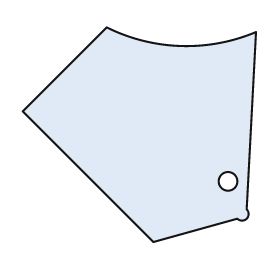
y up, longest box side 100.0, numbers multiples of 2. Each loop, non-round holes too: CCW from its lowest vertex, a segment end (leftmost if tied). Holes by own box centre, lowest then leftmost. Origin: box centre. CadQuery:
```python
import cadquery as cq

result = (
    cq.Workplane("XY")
    .moveTo(6.0, -46.0)
    .lineTo(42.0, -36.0)
    .threePointArc((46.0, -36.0), (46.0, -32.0))
    .lineTo(50.0, 44.0)
    .threePointArc((18.0, 38.0), (-14.0, 46.0))
    .lineTo(-50.0, 10.0)
    .close()
    .moveTo(38.0, -20.0)
    .circle(4.0)
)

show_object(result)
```